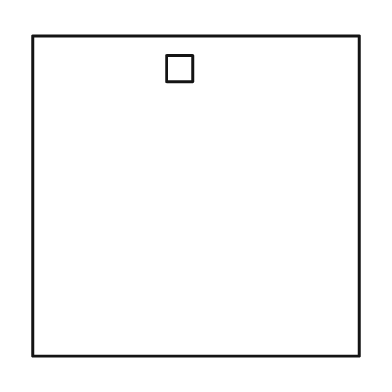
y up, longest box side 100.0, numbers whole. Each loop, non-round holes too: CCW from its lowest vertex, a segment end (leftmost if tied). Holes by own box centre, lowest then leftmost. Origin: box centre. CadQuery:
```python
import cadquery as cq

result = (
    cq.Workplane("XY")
    .moveTo(-50.0, -49.0)
    .lineTo(50.0, -49.0)
    .lineTo(50.0, 49.0)
    .lineTo(-50.0, 49.0)
    .close()
    .moveTo(-9.0, 35.0)
    .lineTo(-1.0, 35.0)
    .lineTo(-1.0, 43.0)
    .lineTo(-9.0, 43.0)
    .close()
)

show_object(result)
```